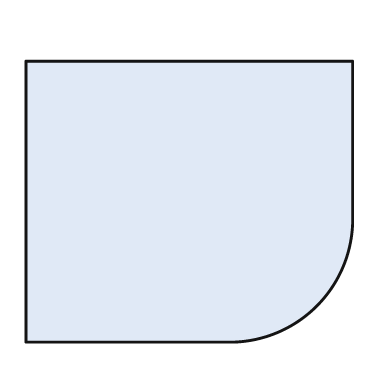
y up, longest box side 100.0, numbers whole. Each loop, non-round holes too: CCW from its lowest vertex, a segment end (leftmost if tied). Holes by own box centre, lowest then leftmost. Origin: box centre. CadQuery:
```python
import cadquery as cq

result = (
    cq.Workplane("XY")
    .moveTo(-50.0, -43.0)
    .lineTo(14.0, -43.0)
    .threePointArc((39.0, -32.0), (50.0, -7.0))
    .lineTo(50.0, 43.0)
    .lineTo(-50.0, 43.0)
    .close()
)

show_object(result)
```